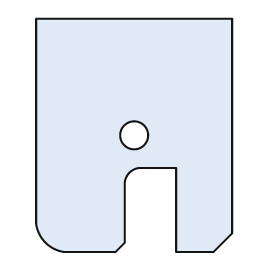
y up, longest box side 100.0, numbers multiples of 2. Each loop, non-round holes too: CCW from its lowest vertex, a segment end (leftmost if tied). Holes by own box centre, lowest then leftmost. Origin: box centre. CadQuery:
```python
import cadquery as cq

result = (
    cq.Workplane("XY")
    .moveTo(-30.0, -50.0)
    .lineTo(-8.0, -50.0)
    .lineTo(-4.0, -46.0)
    .lineTo(-4.0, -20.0)
    .threePointArc((-2.0, -16.0), (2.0, -14.0))
    .lineTo(18.0, -14.0)
    .lineTo(18.0, -50.0)
    .lineTo(34.0, -50.0)
    .lineTo(42.0, -42.0)
    .lineTo(42.0, 50.0)
    .lineTo(-42.0, 50.0)
    .lineTo(-42.0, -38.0)
    .threePointArc((-38.0, -46.0), (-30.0, -50.0))
    .close()
    .moveTo(0.0, 0.0)
    .circle(6.0)
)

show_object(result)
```